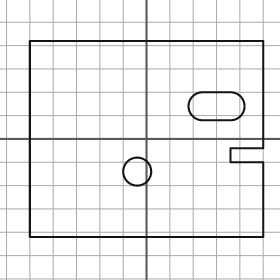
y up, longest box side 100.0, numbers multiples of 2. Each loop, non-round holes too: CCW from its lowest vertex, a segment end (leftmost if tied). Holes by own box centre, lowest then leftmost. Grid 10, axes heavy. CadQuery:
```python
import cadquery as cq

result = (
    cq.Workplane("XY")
    .moveTo(-50.0, -42.0)
    .lineTo(50.0, -42.0)
    .lineTo(50.0, -10.0)
    .lineTo(36.0, -10.0)
    .lineTo(36.0, -4.0)
    .lineTo(50.0, -4.0)
    .lineTo(50.0, 42.0)
    .lineTo(-50.0, 42.0)
    .close()
    .moveTo(-4.0, -14.0)
    .circle(6.0)
    .moveTo(24.0, 8.0)
    .lineTo(36.0, 8.0)
    .threePointArc((42.0, 14.0), (36.0, 20.0))
    .lineTo(24.0, 20.0)
    .threePointArc((18.0, 14.0), (24.0, 8.0))
    .close()
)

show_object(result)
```